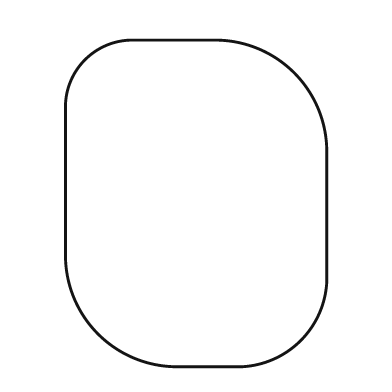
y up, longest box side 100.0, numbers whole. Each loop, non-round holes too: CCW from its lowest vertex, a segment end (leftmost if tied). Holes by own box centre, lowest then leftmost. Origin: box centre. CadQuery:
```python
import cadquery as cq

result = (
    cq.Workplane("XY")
    .moveTo(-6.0, -50.0)
    .lineTo(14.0, -50.0)
    .threePointArc((32.0, -42.0), (40.0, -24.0))
    .lineTo(40.0, 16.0)
    .threePointArc((30.0, 40.0), (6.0, 50.0))
    .lineTo(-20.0, 50.0)
    .threePointArc((-34.0, 44.0), (-40.0, 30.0))
    .lineTo(-40.0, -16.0)
    .threePointArc((-30.0, -40.0), (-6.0, -50.0))
    .close()
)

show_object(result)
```